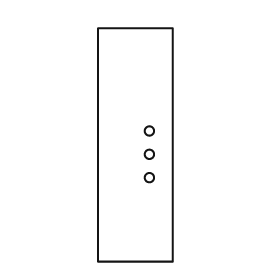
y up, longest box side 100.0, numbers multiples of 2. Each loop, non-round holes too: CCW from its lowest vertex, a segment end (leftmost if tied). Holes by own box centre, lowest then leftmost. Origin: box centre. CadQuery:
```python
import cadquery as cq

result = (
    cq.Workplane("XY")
    .moveTo(-16.0, -50.0)
    .lineTo(16.0, -50.0)
    .lineTo(16.0, 50.0)
    .lineTo(-16.0, 50.0)
    .close()
    .moveTo(6.0, -14.0)
    .circle(2.0)
    .moveTo(6.0, -4.0)
    .circle(2.0)
    .moveTo(6.0, 6.0)
    .circle(2.0)
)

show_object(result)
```